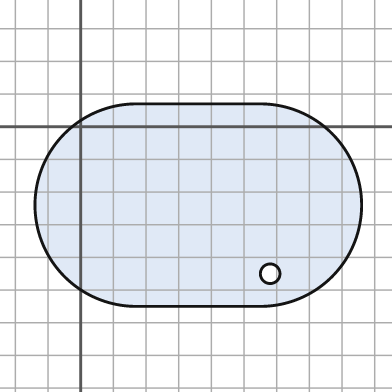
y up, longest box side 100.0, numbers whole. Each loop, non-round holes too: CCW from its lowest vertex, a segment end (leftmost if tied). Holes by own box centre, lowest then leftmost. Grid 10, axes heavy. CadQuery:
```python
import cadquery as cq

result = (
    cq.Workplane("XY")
    .moveTo(17.0, -55.0)
    .lineTo(55.0, -55.0)
    .threePointArc((86.0, -24.0), (55.0, 7.0))
    .lineTo(17.0, 7.0)
    .threePointArc((-14.0, -24.0), (17.0, -55.0))
    .close()
    .moveTo(58.0, -45.0)
    .circle(3.0)
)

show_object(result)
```